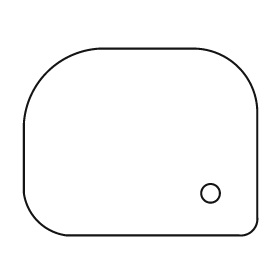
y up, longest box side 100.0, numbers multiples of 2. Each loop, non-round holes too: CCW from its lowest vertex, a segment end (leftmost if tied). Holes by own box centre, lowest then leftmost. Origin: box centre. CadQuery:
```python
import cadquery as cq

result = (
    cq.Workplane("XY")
    .moveTo(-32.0, -40.0)
    .lineTo(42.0, -40.0)
    .threePointArc((48.0, -38.0), (50.0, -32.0))
    .lineTo(50.0, 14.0)
    .threePointArc((42.0, 32.0), (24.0, 40.0))
    .lineTo(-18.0, 40.0)
    .threePointArc((-40.0, 30.0), (-50.0, 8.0))
    .lineTo(-50.0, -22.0)
    .threePointArc((-44.0, -34.0), (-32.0, -40.0))
    .close()
    .moveTo(30.0, -22.0)
    .circle(4.0)
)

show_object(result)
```